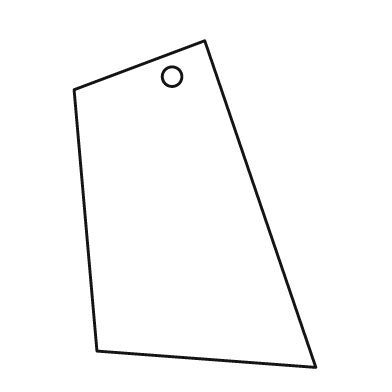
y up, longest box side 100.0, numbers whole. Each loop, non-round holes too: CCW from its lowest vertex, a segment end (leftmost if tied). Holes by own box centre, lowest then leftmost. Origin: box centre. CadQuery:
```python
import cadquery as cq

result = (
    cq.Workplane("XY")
    .moveTo(37.0, -50.0)
    .lineTo(3.0, 50.0)
    .lineTo(-37.0, 35.0)
    .lineTo(-30.0, -45.0)
    .close()
    .moveTo(-7.0, 39.0)
    .circle(3.0)
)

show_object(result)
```